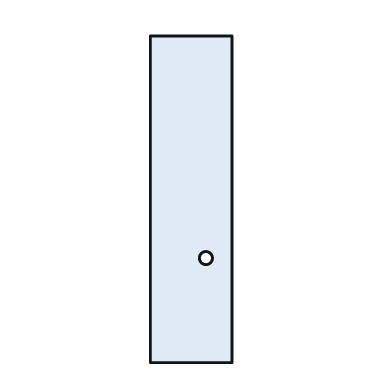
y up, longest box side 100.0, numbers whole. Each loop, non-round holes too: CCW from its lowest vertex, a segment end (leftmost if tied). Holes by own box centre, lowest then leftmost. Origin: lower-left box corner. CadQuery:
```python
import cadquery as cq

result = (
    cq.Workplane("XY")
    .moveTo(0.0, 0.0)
    .lineTo(25.0, 0.0)
    .lineTo(25.0, 100.0)
    .lineTo(0.0, 100.0)
    .close()
    .moveTo(17.0, 32.0)
    .circle(2.0)
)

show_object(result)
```